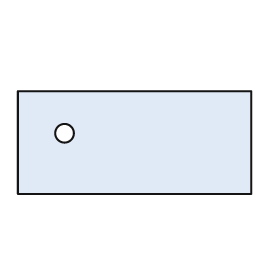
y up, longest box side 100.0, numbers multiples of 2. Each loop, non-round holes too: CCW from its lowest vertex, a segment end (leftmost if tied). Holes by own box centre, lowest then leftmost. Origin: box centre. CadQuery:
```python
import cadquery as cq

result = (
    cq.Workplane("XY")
    .moveTo(-50.0, -22.0)
    .lineTo(50.0, -22.0)
    .lineTo(50.0, 22.0)
    .lineTo(-50.0, 22.0)
    .close()
    .moveTo(-30.0, 4.0)
    .circle(4.0)
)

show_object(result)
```